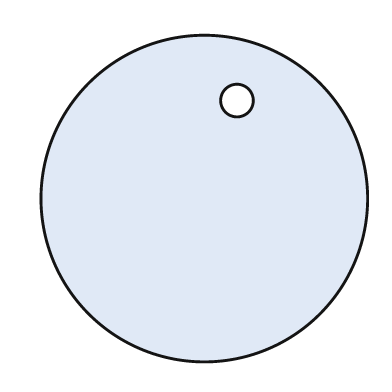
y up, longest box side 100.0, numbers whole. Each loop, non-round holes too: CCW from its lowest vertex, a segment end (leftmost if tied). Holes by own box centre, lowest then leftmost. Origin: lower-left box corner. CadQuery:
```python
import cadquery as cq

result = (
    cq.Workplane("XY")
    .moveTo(50.0, 50.0)
    .circle(50.0)
    .moveTo(60.0, 80.0)
    .circle(5.0)
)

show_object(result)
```